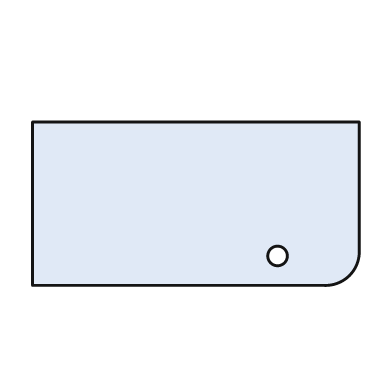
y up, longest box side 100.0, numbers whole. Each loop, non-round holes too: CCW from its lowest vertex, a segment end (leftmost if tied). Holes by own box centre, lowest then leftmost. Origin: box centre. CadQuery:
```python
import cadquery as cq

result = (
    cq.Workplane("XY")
    .moveTo(-50.0, -25.0)
    .lineTo(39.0, -25.0)
    .threePointArc((47.0, -22.0), (50.0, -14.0))
    .lineTo(50.0, 25.0)
    .lineTo(-50.0, 25.0)
    .close()
    .moveTo(25.0, -16.0)
    .circle(3.0)
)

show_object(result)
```